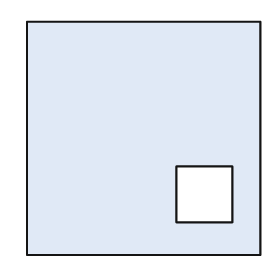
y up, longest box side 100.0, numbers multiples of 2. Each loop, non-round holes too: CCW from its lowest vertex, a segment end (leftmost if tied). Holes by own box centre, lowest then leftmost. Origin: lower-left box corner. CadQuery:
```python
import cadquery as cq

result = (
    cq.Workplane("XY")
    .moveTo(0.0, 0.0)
    .lineTo(100.0, 0.0)
    .lineTo(100.0, 100.0)
    .lineTo(0.0, 100.0)
    .close()
    .moveTo(64.0, 14.0)
    .lineTo(88.0, 14.0)
    .lineTo(88.0, 38.0)
    .lineTo(64.0, 38.0)
    .close()
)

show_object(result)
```